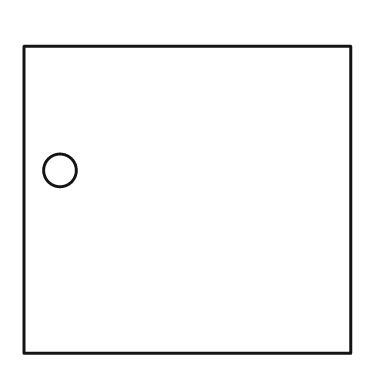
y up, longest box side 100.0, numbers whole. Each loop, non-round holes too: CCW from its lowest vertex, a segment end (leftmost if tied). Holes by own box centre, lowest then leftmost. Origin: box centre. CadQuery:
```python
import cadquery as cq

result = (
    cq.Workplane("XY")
    .moveTo(-50.0, -47.0)
    .lineTo(50.0, -47.0)
    .lineTo(50.0, 47.0)
    .lineTo(-50.0, 47.0)
    .close()
    .moveTo(-39.0, 9.0)
    .circle(5.0)
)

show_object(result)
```